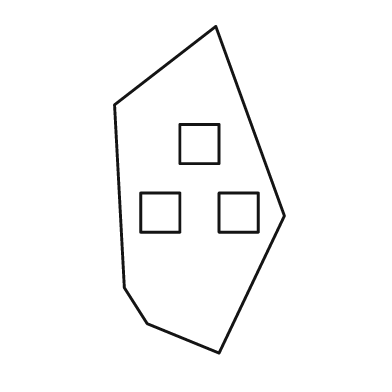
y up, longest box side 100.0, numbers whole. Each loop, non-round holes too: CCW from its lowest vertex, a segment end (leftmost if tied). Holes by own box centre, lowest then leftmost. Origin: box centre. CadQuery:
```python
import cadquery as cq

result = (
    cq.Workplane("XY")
    .moveTo(6.0, -50.0)
    .lineTo(26.0, -8.0)
    .lineTo(5.0, 50.0)
    .lineTo(-26.0, 26.0)
    .lineTo(-23.0, -30.0)
    .lineTo(-16.0, -41.0)
    .close()
    .moveTo(-18.0, -13.0)
    .lineTo(-6.0, -13.0)
    .lineTo(-6.0, -1.0)
    .lineTo(-18.0, -1.0)
    .close()
    .moveTo(6.0, -13.0)
    .lineTo(18.0, -13.0)
    .lineTo(18.0, -1.0)
    .lineTo(6.0, -1.0)
    .close()
    .moveTo(-6.0, 8.0)
    .lineTo(6.0, 8.0)
    .lineTo(6.0, 20.0)
    .lineTo(-6.0, 20.0)
    .close()
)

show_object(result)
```